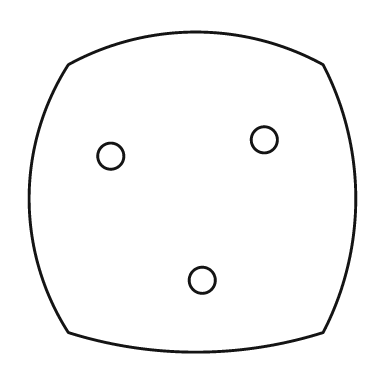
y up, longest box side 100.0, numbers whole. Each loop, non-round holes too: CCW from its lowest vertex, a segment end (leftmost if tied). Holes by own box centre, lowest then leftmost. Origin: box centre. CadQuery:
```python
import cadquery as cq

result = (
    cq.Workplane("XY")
    .moveTo(-38.0, -43.0)
    .threePointArc((1.0, -49.0), (40.0, -43.0))
    .threePointArc((50.0, -2.0), (40.0, 39.0))
    .threePointArc((1.0, 49.0), (-38.0, 39.0))
    .threePointArc((-50.0, -2.0), (-38.0, -43.0))
    .close()
    .moveTo(3.0, -27.0)
    .circle(4.0)
    .moveTo(-25.0, 11.0)
    .circle(4.0)
    .moveTo(22.0, 16.0)
    .circle(4.0)
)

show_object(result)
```